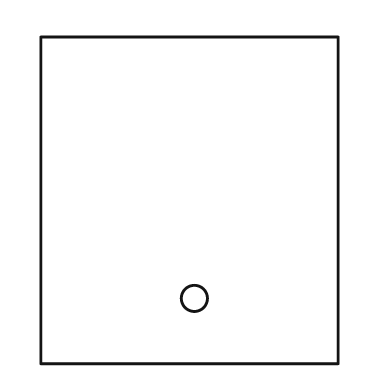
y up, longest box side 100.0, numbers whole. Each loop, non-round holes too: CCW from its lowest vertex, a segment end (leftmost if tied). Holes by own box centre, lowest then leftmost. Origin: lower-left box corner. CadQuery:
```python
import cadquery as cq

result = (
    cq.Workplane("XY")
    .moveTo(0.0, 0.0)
    .lineTo(91.0, 0.0)
    .lineTo(91.0, 100.0)
    .lineTo(0.0, 100.0)
    .close()
    .moveTo(47.0, 20.0)
    .circle(4.0)
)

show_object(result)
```